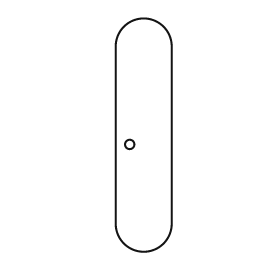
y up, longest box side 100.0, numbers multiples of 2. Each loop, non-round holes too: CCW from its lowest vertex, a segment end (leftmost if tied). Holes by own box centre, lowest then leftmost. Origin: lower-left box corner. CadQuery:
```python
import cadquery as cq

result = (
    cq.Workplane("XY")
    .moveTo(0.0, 12.0)
    .threePointArc((12.0, 0.0), (24.0, 12.0))
    .lineTo(24.0, 88.0)
    .threePointArc((12.0, 100.0), (0.0, 88.0))
    .close()
    .moveTo(6.0, 46.0)
    .circle(2.0)
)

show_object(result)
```